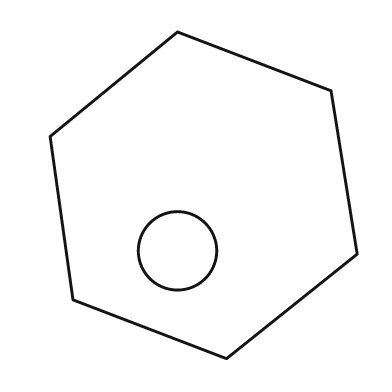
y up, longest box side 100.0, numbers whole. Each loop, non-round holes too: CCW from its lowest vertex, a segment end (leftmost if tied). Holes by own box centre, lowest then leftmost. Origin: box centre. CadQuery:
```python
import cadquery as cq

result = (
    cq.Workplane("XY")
    .moveTo(7.0, -50.0)
    .lineTo(47.0, -18.0)
    .lineTo(39.0, 32.0)
    .lineTo(-8.0, 50.0)
    .lineTo(-47.0, 18.0)
    .lineTo(-40.0, -32.0)
    .close()
    .moveTo(-8.0, -17.0)
    .circle(12.0)
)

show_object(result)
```